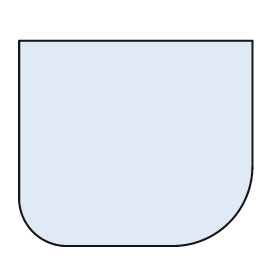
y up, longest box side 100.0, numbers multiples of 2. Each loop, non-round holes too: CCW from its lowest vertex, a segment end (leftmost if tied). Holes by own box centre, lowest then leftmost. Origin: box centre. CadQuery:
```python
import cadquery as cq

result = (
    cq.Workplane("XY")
    .moveTo(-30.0, -44.0)
    .lineTo(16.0, -44.0)
    .threePointArc((40.0, -34.0), (50.0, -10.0))
    .lineTo(50.0, 44.0)
    .lineTo(-50.0, 44.0)
    .lineTo(-50.0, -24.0)
    .threePointArc((-44.0, -38.0), (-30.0, -44.0))
    .close()
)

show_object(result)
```